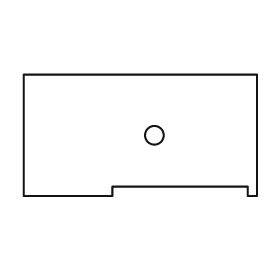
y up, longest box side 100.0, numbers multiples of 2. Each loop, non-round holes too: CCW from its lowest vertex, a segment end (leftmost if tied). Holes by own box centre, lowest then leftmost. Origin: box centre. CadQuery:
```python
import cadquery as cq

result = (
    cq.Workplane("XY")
    .moveTo(-50.0, -26.0)
    .lineTo(-12.0, -26.0)
    .lineTo(-12.0, -22.0)
    .lineTo(46.0, -22.0)
    .lineTo(46.0, -26.0)
    .lineTo(50.0, -26.0)
    .lineTo(50.0, 26.0)
    .lineTo(-50.0, 26.0)
    .close()
    .moveTo(6.0, 0.0)
    .circle(4.0)
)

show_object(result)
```